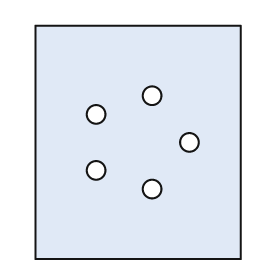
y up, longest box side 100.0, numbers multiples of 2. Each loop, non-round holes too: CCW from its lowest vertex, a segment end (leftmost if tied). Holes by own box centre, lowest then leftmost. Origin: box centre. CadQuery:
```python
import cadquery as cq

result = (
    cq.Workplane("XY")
    .moveTo(-44.0, -50.0)
    .lineTo(44.0, -50.0)
    .lineTo(44.0, 50.0)
    .lineTo(-44.0, 50.0)
    .close()
    .moveTo(6.0, -20.0)
    .circle(4.0)
    .moveTo(-18.0, -12.0)
    .circle(4.0)
    .moveTo(22.0, 0.0)
    .circle(4.0)
    .moveTo(-18.0, 12.0)
    .circle(4.0)
    .moveTo(6.0, 20.0)
    .circle(4.0)
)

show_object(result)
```